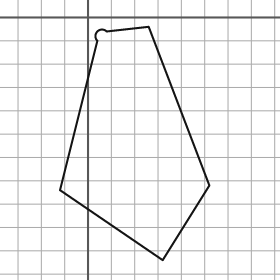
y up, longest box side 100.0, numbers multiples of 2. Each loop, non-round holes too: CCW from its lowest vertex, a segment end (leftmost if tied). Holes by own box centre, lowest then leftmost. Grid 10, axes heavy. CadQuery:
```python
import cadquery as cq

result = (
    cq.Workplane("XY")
    .moveTo(32.0, -104.0)
    .lineTo(52.0, -72.0)
    .lineTo(26.0, -4.0)
    .lineTo(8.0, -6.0)
    .threePointArc((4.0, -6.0), (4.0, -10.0))
    .lineTo(-12.0, -74.0)
    .close()
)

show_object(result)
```